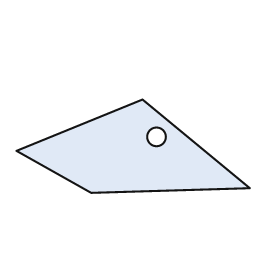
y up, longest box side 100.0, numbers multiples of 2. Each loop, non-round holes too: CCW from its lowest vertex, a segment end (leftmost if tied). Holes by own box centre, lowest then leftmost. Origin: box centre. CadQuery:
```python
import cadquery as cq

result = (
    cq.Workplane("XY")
    .moveTo(-18.0, -20.0)
    .lineTo(50.0, -18.0)
    .lineTo(4.0, 20.0)
    .lineTo(-50.0, -2.0)
    .close()
    .moveTo(10.0, 4.0)
    .circle(4.0)
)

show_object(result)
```